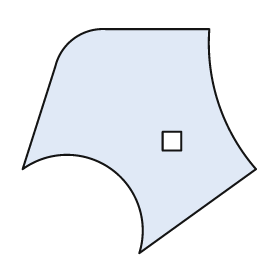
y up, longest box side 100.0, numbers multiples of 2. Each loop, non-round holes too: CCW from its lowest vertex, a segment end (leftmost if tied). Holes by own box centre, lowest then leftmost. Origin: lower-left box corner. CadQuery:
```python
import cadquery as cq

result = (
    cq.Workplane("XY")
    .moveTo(50.0, 0.0)
    .lineTo(100.0, 36.0)
    .threePointArc((84.0, 64.0), (80.0, 96.0))
    .lineTo(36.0, 96.0)
    .threePointArc((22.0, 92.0), (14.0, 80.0))
    .lineTo(0.0, 36.0)
    .threePointArc((38.0, 36.0), (50.0, 0.0))
    .close()
    .moveTo(60.0, 44.0)
    .lineTo(68.0, 44.0)
    .lineTo(68.0, 52.0)
    .lineTo(60.0, 52.0)
    .close()
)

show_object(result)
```